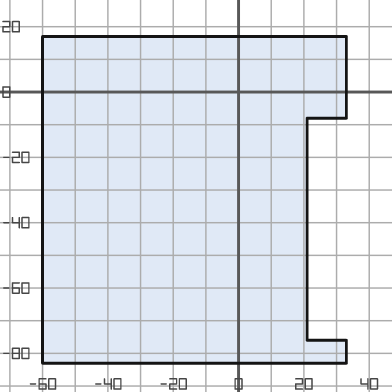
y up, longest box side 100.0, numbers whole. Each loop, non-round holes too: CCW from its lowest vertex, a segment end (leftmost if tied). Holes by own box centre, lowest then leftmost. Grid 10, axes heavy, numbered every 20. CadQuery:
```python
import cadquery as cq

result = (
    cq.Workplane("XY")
    .moveTo(-60.0, -83.0)
    .lineTo(33.0, -83.0)
    .lineTo(33.0, -76.0)
    .lineTo(21.0, -76.0)
    .lineTo(21.0, -8.0)
    .lineTo(33.0, -8.0)
    .lineTo(33.0, 17.0)
    .lineTo(-60.0, 17.0)
    .close()
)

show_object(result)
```